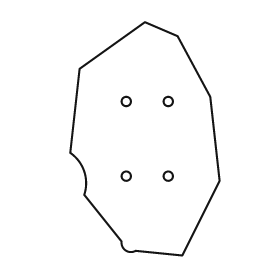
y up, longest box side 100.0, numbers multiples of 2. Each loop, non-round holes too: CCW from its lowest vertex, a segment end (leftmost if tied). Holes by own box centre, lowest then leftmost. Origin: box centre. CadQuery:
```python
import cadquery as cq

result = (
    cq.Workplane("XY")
    .moveTo(16.0, -50.0)
    .lineTo(32.0, -18.0)
    .lineTo(28.0, 18.0)
    .lineTo(14.0, 44.0)
    .lineTo(0.0, 50.0)
    .lineTo(-28.0, 30.0)
    .lineTo(-32.0, -6.0)
    .threePointArc((-26.0, -14.0), (-26.0, -24.0))
    .lineTo(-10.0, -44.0)
    .threePointArc((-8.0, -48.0), (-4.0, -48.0))
    .close()
    .moveTo(-8.0, -16.0)
    .circle(2.0)
    .moveTo(10.0, -16.0)
    .circle(2.0)
    .moveTo(-8.0, 16.0)
    .circle(2.0)
    .moveTo(10.0, 16.0)
    .circle(2.0)
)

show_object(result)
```